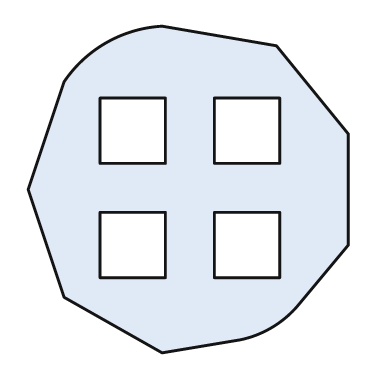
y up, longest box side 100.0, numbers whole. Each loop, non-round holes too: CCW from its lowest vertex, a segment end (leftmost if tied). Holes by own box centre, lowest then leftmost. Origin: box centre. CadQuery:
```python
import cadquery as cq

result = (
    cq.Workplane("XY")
    .moveTo(-8.0, -50.0)
    .lineTo(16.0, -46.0)
    .threePointArc((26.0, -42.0), (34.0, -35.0))
    .lineTo(49.0, -17.0)
    .lineTo(49.0, 17.0)
    .lineTo(27.0, 44.0)
    .lineTo(-8.0, 50.0)
    .threePointArc((-25.0, 45.0), (-38.0, 33.0))
    .lineTo(-49.0, 0.0)
    .lineTo(-38.0, -33.0)
    .close()
    .moveTo(-27.0, -27.0)
    .lineTo(-7.0, -27.0)
    .lineTo(-7.0, -7.0)
    .lineTo(-27.0, -7.0)
    .close()
    .moveTo(8.0, -27.0)
    .lineTo(28.0, -27.0)
    .lineTo(28.0, -7.0)
    .lineTo(8.0, -7.0)
    .close()
    .moveTo(-27.0, 8.0)
    .lineTo(-7.0, 8.0)
    .lineTo(-7.0, 28.0)
    .lineTo(-27.0, 28.0)
    .close()
    .moveTo(8.0, 8.0)
    .lineTo(28.0, 8.0)
    .lineTo(28.0, 28.0)
    .lineTo(8.0, 28.0)
    .close()
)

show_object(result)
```